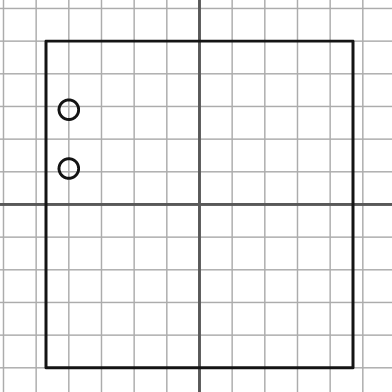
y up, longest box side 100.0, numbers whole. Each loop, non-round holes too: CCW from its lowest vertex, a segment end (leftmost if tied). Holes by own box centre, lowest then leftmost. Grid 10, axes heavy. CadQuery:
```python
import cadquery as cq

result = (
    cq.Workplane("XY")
    .moveTo(-47.0, -50.0)
    .lineTo(47.0, -50.0)
    .lineTo(47.0, 50.0)
    .lineTo(-47.0, 50.0)
    .close()
    .moveTo(-40.0, 11.0)
    .circle(3.0)
    .moveTo(-40.0, 29.0)
    .circle(3.0)
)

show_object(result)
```